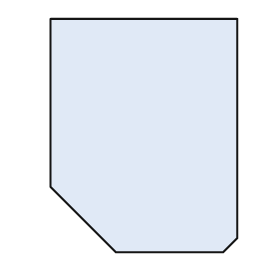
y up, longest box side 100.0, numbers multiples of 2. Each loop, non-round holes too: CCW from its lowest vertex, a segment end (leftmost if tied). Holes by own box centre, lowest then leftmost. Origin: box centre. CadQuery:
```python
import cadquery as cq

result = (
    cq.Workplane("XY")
    .moveTo(-12.0, -50.0)
    .lineTo(34.0, -50.0)
    .lineTo(40.0, -44.0)
    .lineTo(40.0, 50.0)
    .lineTo(-40.0, 50.0)
    .lineTo(-40.0, -22.0)
    .close()
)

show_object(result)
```